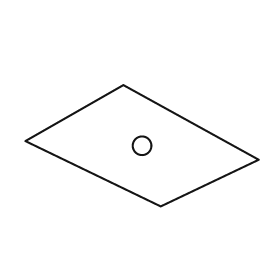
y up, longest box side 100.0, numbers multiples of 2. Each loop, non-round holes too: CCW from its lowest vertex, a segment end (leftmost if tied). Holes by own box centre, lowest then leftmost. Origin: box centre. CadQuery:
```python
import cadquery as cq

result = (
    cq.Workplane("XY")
    .moveTo(8.0, -26.0)
    .lineTo(50.0, -6.0)
    .lineTo(-8.0, 26.0)
    .lineTo(-50.0, 2.0)
    .close()
    .moveTo(0.0, 0.0)
    .circle(4.0)
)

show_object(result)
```